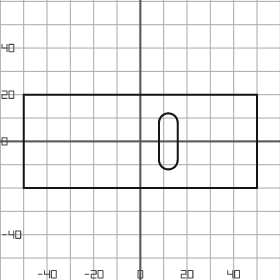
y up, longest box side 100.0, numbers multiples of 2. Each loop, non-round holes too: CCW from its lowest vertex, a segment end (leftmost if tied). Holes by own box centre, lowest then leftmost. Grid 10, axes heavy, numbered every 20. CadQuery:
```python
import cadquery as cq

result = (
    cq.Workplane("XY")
    .moveTo(-50.0, -20.0)
    .lineTo(50.0, -20.0)
    .lineTo(50.0, 20.0)
    .lineTo(-50.0, 20.0)
    .close()
    .moveTo(8.0, -8.0)
    .threePointArc((12.0, -12.0), (16.0, -8.0))
    .lineTo(16.0, 8.0)
    .threePointArc((12.0, 12.0), (8.0, 8.0))
    .close()
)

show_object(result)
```